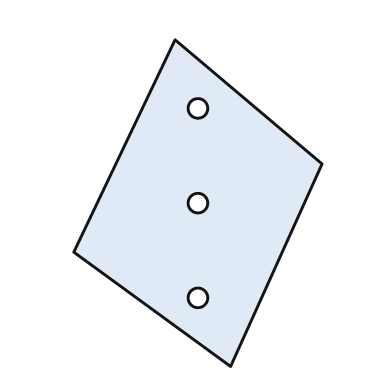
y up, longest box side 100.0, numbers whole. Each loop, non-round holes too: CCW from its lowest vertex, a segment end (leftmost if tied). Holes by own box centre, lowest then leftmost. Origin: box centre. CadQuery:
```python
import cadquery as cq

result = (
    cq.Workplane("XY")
    .moveTo(10.0, -50.0)
    .lineTo(38.0, 12.0)
    .lineTo(-7.0, 50.0)
    .lineTo(-38.0, -15.0)
    .close()
    .moveTo(0.0, -29.0)
    .circle(3.0)
    .moveTo(0.0, 0.0)
    .circle(3.0)
    .moveTo(0.0, 29.0)
    .circle(3.0)
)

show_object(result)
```